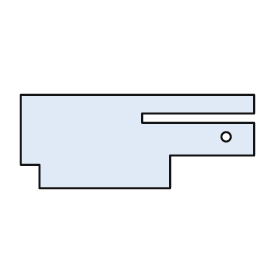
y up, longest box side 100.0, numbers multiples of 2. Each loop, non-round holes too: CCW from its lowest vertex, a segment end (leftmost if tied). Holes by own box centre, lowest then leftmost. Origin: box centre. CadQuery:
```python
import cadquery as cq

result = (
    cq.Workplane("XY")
    .moveTo(-42.0, -20.0)
    .lineTo(14.0, -20.0)
    .lineTo(14.0, -6.0)
    .lineTo(50.0, -6.0)
    .lineTo(50.0, 8.0)
    .lineTo(2.0, 8.0)
    .lineTo(2.0, 12.0)
    .lineTo(50.0, 12.0)
    .lineTo(50.0, 20.0)
    .lineTo(-50.0, 20.0)
    .lineTo(-50.0, -10.0)
    .lineTo(-42.0, -10.0)
    .close()
    .moveTo(38.0, 2.0)
    .circle(2.0)
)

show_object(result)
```